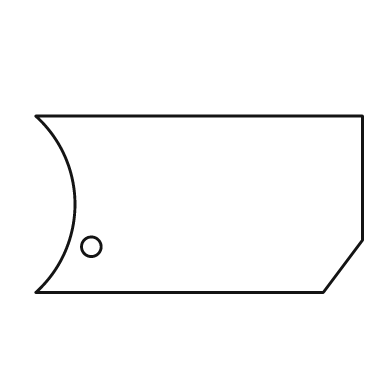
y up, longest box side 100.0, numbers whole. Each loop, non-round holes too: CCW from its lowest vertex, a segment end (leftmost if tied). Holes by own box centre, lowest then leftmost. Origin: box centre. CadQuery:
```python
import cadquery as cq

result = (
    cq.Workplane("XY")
    .moveTo(-50.0, -27.0)
    .lineTo(38.0, -27.0)
    .lineTo(50.0, -11.0)
    .lineTo(50.0, 27.0)
    .lineTo(-50.0, 27.0)
    .threePointArc((-38.0, 0.0), (-50.0, -27.0))
    .close()
    .moveTo(-33.0, -13.0)
    .circle(3.0)
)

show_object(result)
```